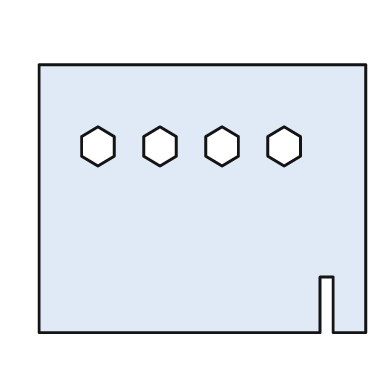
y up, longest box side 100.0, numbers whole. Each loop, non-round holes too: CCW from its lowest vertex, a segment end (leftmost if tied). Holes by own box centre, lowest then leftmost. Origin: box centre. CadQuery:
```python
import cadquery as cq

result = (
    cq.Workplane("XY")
    .moveTo(-50.0, -41.0)
    .lineTo(36.0, -41.0)
    .lineTo(36.0, -24.0)
    .lineTo(40.0, -24.0)
    .lineTo(40.0, -41.0)
    .lineTo(50.0, -41.0)
    .lineTo(50.0, 41.0)
    .lineTo(-50.0, 41.0)
    .close()
    .moveTo(-32.0, 10.0)
    .lineTo(-27.0, 13.0)
    .lineTo(-27.0, 19.0)
    .lineTo(-32.0, 22.0)
    .lineTo(-37.0, 19.0)
    .lineTo(-37.0, 13.0)
    .close()
    .moveTo(-13.0, 10.0)
    .lineTo(-8.0, 13.0)
    .lineTo(-8.0, 19.0)
    .lineTo(-13.0, 22.0)
    .lineTo(-18.0, 19.0)
    .lineTo(-18.0, 13.0)
    .close()
    .moveTo(6.0, 10.0)
    .lineTo(11.0, 13.0)
    .lineTo(11.0, 19.0)
    .lineTo(6.0, 22.0)
    .lineTo(1.0, 19.0)
    .lineTo(1.0, 13.0)
    .close()
    .moveTo(25.0, 10.0)
    .lineTo(30.0, 13.0)
    .lineTo(30.0, 19.0)
    .lineTo(25.0, 22.0)
    .lineTo(20.0, 19.0)
    .lineTo(20.0, 13.0)
    .close()
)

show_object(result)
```